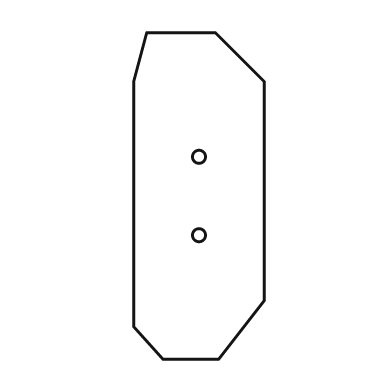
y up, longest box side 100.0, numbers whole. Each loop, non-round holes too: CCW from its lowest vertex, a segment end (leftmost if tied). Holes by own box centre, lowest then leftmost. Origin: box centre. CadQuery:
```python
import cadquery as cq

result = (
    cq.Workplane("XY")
    .moveTo(-11.0, -50.0)
    .lineTo(6.0, -50.0)
    .lineTo(20.0, -32.0)
    .lineTo(20.0, 35.0)
    .lineTo(5.0, 50.0)
    .lineTo(-16.0, 50.0)
    .lineTo(-20.0, 35.0)
    .lineTo(-20.0, -40.0)
    .close()
    .moveTo(0.0, -12.0)
    .circle(2.0)
    .moveTo(0.0, 12.0)
    .circle(2.0)
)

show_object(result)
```